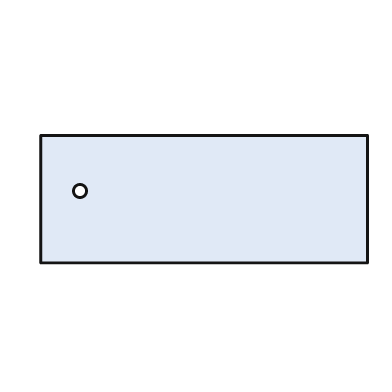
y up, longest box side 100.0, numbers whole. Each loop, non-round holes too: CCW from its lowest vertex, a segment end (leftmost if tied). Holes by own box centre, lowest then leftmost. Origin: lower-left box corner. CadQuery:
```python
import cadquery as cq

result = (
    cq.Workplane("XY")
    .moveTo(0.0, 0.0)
    .lineTo(100.0, 0.0)
    .lineTo(100.0, 39.0)
    .lineTo(0.0, 39.0)
    .close()
    .moveTo(12.0, 22.0)
    .circle(2.0)
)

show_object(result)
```